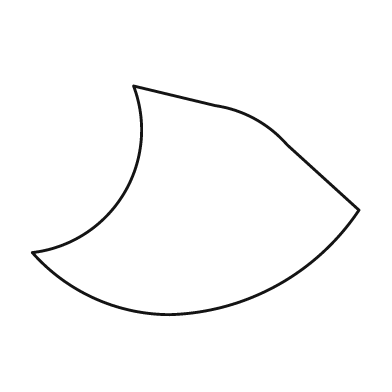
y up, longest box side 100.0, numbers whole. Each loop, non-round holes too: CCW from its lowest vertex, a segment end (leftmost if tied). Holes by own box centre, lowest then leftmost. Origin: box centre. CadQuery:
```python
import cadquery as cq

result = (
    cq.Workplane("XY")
    .moveTo(-8.0, -35.0)
    .threePointArc((25.0, -26.0), (50.0, -3.0))
    .lineTo(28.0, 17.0)
    .threePointArc((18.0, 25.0), (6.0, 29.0))
    .lineTo(-19.0, 35.0)
    .threePointArc((-22.0, 2.0), (-50.0, -16.0))
    .threePointArc((-31.0, -30.0), (-8.0, -35.0))
    .close()
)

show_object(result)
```